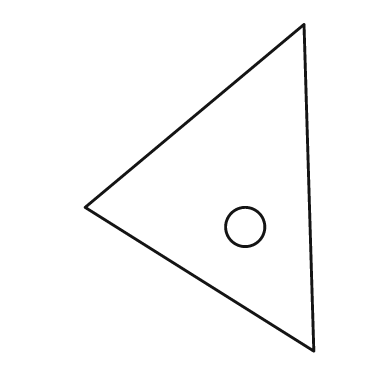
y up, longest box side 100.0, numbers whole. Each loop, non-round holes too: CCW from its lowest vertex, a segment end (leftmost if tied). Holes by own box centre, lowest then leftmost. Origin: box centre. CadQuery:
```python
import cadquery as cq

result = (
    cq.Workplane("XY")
    .moveTo(35.0, -50.0)
    .lineTo(32.0, 50.0)
    .lineTo(-35.0, -6.0)
    .close()
    .moveTo(14.0, -12.0)
    .circle(6.0)
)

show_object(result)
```